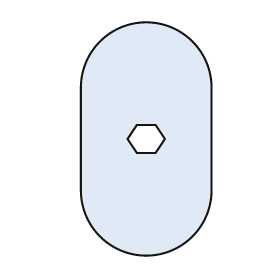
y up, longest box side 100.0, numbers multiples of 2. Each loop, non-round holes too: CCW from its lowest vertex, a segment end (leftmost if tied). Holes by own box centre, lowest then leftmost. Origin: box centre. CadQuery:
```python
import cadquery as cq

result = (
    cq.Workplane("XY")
    .moveTo(-28.0, -22.0)
    .threePointArc((0.0, -50.0), (28.0, -22.0))
    .lineTo(28.0, 22.0)
    .threePointArc((0.0, 50.0), (-28.0, 22.0))
    .close()
    .moveTo(-4.0, -6.0)
    .lineTo(4.0, -6.0)
    .lineTo(8.0, 0.0)
    .lineTo(4.0, 6.0)
    .lineTo(-4.0, 6.0)
    .lineTo(-8.0, 0.0)
    .close()
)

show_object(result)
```